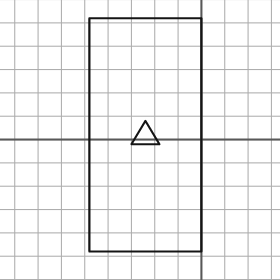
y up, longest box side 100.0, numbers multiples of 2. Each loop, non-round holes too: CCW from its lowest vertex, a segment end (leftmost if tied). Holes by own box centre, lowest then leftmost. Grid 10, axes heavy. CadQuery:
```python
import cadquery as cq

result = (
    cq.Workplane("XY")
    .moveTo(-48.0, -48.0)
    .lineTo(0.0, -48.0)
    .lineTo(0.0, 52.0)
    .lineTo(-48.0, 52.0)
    .close()
    .moveTo(-30.0, -2.0)
    .lineTo(-18.0, -2.0)
    .lineTo(-24.0, 8.0)
    .close()
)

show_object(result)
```